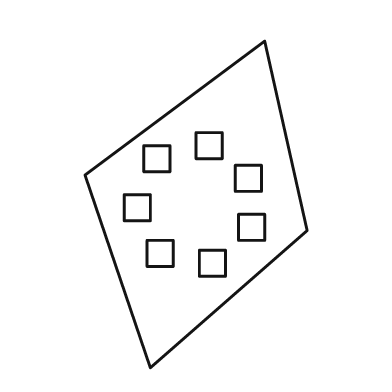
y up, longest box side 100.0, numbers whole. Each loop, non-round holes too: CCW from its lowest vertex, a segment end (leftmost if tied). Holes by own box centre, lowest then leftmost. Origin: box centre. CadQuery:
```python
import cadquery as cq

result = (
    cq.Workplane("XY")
    .moveTo(-14.0, -50.0)
    .lineTo(34.0, -8.0)
    .lineTo(21.0, 50.0)
    .lineTo(-34.0, 9.0)
    .close()
    .moveTo(1.0, -22.0)
    .lineTo(9.0, -22.0)
    .lineTo(9.0, -14.0)
    .lineTo(1.0, -14.0)
    .close()
    .moveTo(-15.0, -19.0)
    .lineTo(-7.0, -19.0)
    .lineTo(-7.0, -11.0)
    .lineTo(-15.0, -11.0)
    .close()
    .moveTo(13.0, -11.0)
    .lineTo(21.0, -11.0)
    .lineTo(21.0, -3.0)
    .lineTo(13.0, -3.0)
    .close()
    .moveTo(-22.0, -5.0)
    .lineTo(-14.0, -5.0)
    .lineTo(-14.0, 3.0)
    .lineTo(-22.0, 3.0)
    .close()
    .moveTo(12.0, 4.0)
    .lineTo(20.0, 4.0)
    .lineTo(20.0, 12.0)
    .lineTo(12.0, 12.0)
    .close()
    .moveTo(-16.0, 10.0)
    .lineTo(-8.0, 10.0)
    .lineTo(-8.0, 18.0)
    .lineTo(-16.0, 18.0)
    .close()
    .moveTo(0.0, 14.0)
    .lineTo(8.0, 14.0)
    .lineTo(8.0, 22.0)
    .lineTo(0.0, 22.0)
    .close()
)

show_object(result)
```